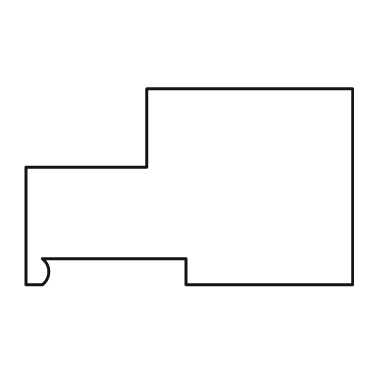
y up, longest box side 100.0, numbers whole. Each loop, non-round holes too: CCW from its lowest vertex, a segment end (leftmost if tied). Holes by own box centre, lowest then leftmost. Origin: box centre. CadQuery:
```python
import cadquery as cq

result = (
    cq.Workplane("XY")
    .moveTo(-50.0, -30.0)
    .lineTo(-45.0, -30.0)
    .threePointArc((-43.0, -26.0), (-45.0, -22.0))
    .lineTo(-1.0, -22.0)
    .lineTo(-1.0, -30.0)
    .lineTo(50.0, -30.0)
    .lineTo(50.0, 30.0)
    .lineTo(-13.0, 30.0)
    .lineTo(-13.0, 6.0)
    .lineTo(-50.0, 6.0)
    .close()
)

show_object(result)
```